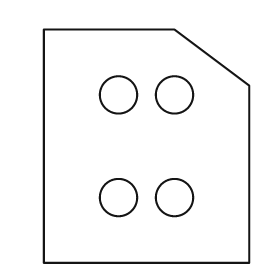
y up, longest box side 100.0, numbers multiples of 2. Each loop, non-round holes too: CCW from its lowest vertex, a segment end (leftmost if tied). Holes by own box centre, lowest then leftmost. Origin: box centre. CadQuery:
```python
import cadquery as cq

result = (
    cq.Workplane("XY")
    .moveTo(-44.0, -50.0)
    .lineTo(44.0, -50.0)
    .lineTo(44.0, 26.0)
    .lineTo(12.0, 50.0)
    .lineTo(-44.0, 50.0)
    .close()
    .moveTo(-12.0, -22.0)
    .circle(8.0)
    .moveTo(12.0, -22.0)
    .circle(8.0)
    .moveTo(-12.0, 22.0)
    .circle(8.0)
    .moveTo(12.0, 22.0)
    .circle(8.0)
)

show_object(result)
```